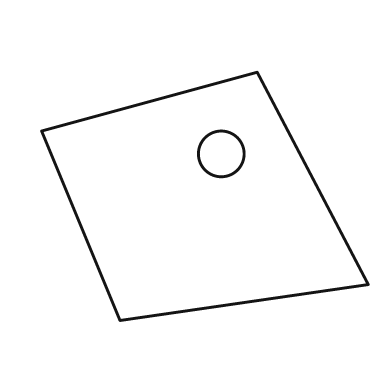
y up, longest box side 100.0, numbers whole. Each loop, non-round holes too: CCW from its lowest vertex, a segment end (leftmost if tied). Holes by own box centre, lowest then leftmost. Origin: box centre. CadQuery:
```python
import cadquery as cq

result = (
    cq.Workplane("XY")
    .moveTo(-26.0, -38.0)
    .lineTo(50.0, -27.0)
    .lineTo(16.0, 38.0)
    .lineTo(-50.0, 20.0)
    .close()
    .moveTo(5.0, 13.0)
    .circle(7.0)
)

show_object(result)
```